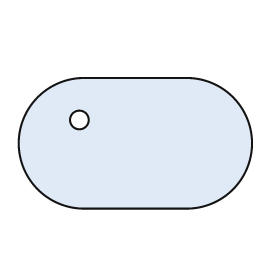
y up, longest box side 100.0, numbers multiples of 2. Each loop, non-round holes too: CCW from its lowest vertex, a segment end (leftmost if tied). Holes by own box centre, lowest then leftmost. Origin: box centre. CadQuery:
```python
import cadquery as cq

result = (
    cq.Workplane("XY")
    .moveTo(-22.0, -28.0)
    .lineTo(22.0, -28.0)
    .threePointArc((50.0, 0.0), (22.0, 28.0))
    .lineTo(-22.0, 28.0)
    .threePointArc((-50.0, 0.0), (-22.0, -28.0))
    .close()
    .moveTo(-24.0, 10.0)
    .circle(4.0)
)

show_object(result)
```